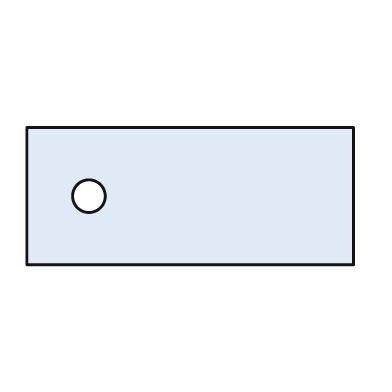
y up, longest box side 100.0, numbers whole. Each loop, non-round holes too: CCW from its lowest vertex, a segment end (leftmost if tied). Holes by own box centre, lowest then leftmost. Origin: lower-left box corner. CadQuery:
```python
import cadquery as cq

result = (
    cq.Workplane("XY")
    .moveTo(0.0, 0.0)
    .lineTo(100.0, 0.0)
    .lineTo(100.0, 42.0)
    .lineTo(0.0, 42.0)
    .close()
    .moveTo(19.0, 21.0)
    .circle(5.0)
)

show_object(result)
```